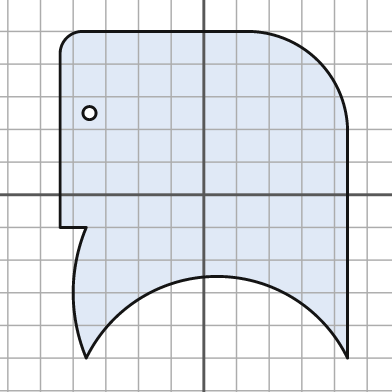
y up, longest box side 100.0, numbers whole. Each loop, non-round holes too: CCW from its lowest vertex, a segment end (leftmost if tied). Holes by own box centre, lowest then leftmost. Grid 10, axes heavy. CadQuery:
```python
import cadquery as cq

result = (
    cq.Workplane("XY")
    .moveTo(-36.0, -50.0)
    .threePointArc((4.0, -25.0), (44.0, -50.0))
    .lineTo(44.0, 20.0)
    .threePointArc((35.0, 41.0), (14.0, 50.0))
    .lineTo(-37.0, 50.0)
    .threePointArc((-42.0, 48.0), (-44.0, 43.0))
    .lineTo(-44.0, -10.0)
    .lineTo(-36.0, -10.0)
    .threePointArc((-40.0, -30.0), (-36.0, -50.0))
    .close()
    .moveTo(-35.0, 25.0)
    .circle(2.0)
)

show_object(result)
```